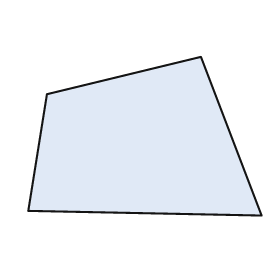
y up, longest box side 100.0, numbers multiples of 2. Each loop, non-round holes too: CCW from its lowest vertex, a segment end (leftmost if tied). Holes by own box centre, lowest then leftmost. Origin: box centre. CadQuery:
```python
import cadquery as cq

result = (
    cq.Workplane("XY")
    .moveTo(50.0, -34.0)
    .lineTo(24.0, 34.0)
    .lineTo(-42.0, 18.0)
    .lineTo(-50.0, -32.0)
    .close()
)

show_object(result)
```